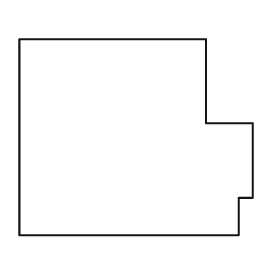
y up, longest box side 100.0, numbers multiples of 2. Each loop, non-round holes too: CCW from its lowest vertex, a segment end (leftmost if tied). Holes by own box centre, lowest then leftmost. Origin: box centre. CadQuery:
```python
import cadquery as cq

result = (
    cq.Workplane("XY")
    .moveTo(-50.0, -42.0)
    .lineTo(44.0, -42.0)
    .lineTo(44.0, -26.0)
    .lineTo(50.0, -26.0)
    .lineTo(50.0, 6.0)
    .lineTo(30.0, 6.0)
    .lineTo(30.0, 42.0)
    .lineTo(-50.0, 42.0)
    .close()
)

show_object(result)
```